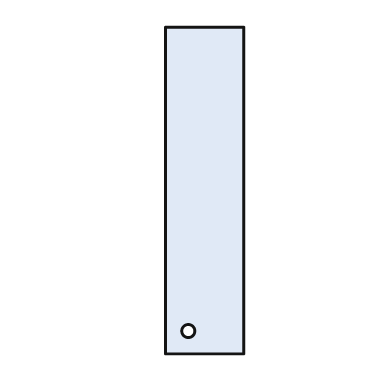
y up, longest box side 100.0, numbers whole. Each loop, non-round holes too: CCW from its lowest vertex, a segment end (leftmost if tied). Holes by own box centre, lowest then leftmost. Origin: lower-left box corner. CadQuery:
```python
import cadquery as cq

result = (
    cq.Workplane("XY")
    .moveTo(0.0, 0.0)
    .lineTo(24.0, 0.0)
    .lineTo(24.0, 100.0)
    .lineTo(0.0, 100.0)
    .close()
    .moveTo(7.0, 7.0)
    .circle(2.0)
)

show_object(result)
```